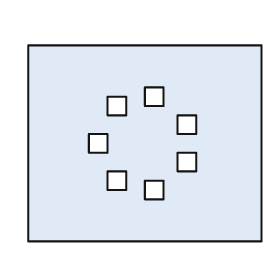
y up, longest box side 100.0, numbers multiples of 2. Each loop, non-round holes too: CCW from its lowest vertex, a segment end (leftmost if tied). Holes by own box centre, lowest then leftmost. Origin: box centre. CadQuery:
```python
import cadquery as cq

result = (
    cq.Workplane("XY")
    .moveTo(-50.0, -42.0)
    .lineTo(50.0, -42.0)
    .lineTo(50.0, 42.0)
    .lineTo(-50.0, 42.0)
    .close()
    .moveTo(0.0, -24.0)
    .lineTo(8.0, -24.0)
    .lineTo(8.0, -16.0)
    .lineTo(0.0, -16.0)
    .close()
    .moveTo(-16.0, -20.0)
    .lineTo(-8.0, -20.0)
    .lineTo(-8.0, -12.0)
    .lineTo(-16.0, -12.0)
    .close()
    .moveTo(14.0, -12.0)
    .lineTo(22.0, -12.0)
    .lineTo(22.0, -4.0)
    .lineTo(14.0, -4.0)
    .close()
    .moveTo(-24.0, -4.0)
    .lineTo(-16.0, -4.0)
    .lineTo(-16.0, 4.0)
    .lineTo(-24.0, 4.0)
    .close()
    .moveTo(14.0, 4.0)
    .lineTo(22.0, 4.0)
    .lineTo(22.0, 12.0)
    .lineTo(14.0, 12.0)
    .close()
    .moveTo(-16.0, 12.0)
    .lineTo(-8.0, 12.0)
    .lineTo(-8.0, 20.0)
    .lineTo(-16.0, 20.0)
    .close()
    .moveTo(0.0, 16.0)
    .lineTo(8.0, 16.0)
    .lineTo(8.0, 24.0)
    .lineTo(0.0, 24.0)
    .close()
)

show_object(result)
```